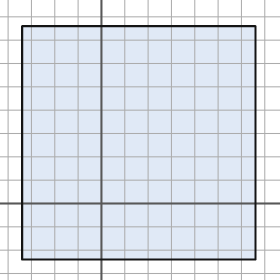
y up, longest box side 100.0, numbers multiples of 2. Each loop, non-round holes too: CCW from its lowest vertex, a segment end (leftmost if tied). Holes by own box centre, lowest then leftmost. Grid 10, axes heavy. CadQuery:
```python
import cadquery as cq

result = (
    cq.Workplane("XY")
    .moveTo(-34.0, -24.0)
    .lineTo(66.0, -24.0)
    .lineTo(66.0, 76.0)
    .lineTo(-34.0, 76.0)
    .close()
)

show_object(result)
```